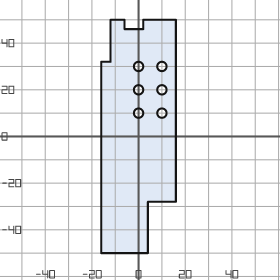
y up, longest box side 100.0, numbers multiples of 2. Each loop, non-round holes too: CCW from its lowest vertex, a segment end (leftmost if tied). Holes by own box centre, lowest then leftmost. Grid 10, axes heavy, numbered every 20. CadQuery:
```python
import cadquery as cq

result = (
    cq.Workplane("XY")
    .moveTo(-16.0, -50.0)
    .lineTo(4.0, -50.0)
    .lineTo(4.0, -28.0)
    .lineTo(16.0, -28.0)
    .lineTo(16.0, 50.0)
    .lineTo(2.0, 50.0)
    .lineTo(2.0, 46.0)
    .lineTo(-6.0, 46.0)
    .lineTo(-6.0, 50.0)
    .lineTo(-12.0, 50.0)
    .lineTo(-12.0, 32.0)
    .lineTo(-16.0, 32.0)
    .close()
    .moveTo(0.0, 10.0)
    .circle(2.0)
    .moveTo(10.0, 10.0)
    .circle(2.0)
    .moveTo(0.0, 20.0)
    .circle(2.0)
    .moveTo(10.0, 20.0)
    .circle(2.0)
    .moveTo(0.0, 30.0)
    .circle(2.0)
    .moveTo(10.0, 30.0)
    .circle(2.0)
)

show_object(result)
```